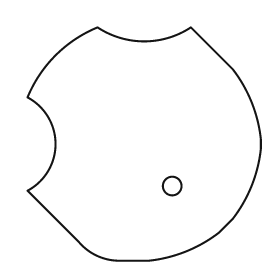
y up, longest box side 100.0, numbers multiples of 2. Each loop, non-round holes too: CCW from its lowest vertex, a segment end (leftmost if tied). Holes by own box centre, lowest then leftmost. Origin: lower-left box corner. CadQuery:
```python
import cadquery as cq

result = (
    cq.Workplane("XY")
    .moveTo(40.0, 0.0)
    .lineTo(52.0, 0.0)
    .threePointArc((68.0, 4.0), (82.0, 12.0))
    .lineTo(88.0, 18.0)
    .threePointArc((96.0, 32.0), (100.0, 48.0))
    .lineTo(100.0, 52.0)
    .threePointArc((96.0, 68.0), (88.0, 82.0))
    .lineTo(70.0, 100.0)
    .threePointArc((50.0, 94.0), (30.0, 100.0))
    .threePointArc((12.0, 88.0), (0.0, 70.0))
    .threePointArc((12.0, 50.0), (0.0, 30.0))
    .lineTo(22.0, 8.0)
    .threePointArc((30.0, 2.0), (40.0, 0.0))
    .close()
    .moveTo(62.0, 32.0)
    .circle(4.0)
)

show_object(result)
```